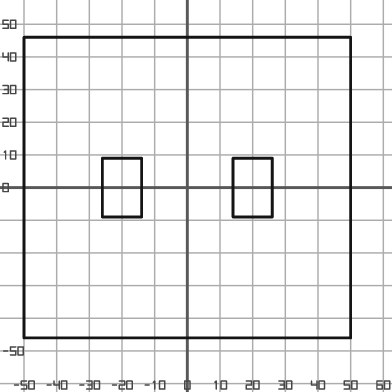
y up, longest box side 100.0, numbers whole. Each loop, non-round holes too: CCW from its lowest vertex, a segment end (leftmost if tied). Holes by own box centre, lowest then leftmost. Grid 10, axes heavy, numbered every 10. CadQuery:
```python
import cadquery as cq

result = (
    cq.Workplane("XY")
    .moveTo(-50.0, -46.0)
    .lineTo(50.0, -46.0)
    .lineTo(50.0, 46.0)
    .lineTo(-50.0, 46.0)
    .close()
    .moveTo(-26.0, -9.0)
    .lineTo(-14.0, -9.0)
    .lineTo(-14.0, 9.0)
    .lineTo(-26.0, 9.0)
    .close()
    .moveTo(14.0, -9.0)
    .lineTo(26.0, -9.0)
    .lineTo(26.0, 9.0)
    .lineTo(14.0, 9.0)
    .close()
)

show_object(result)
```